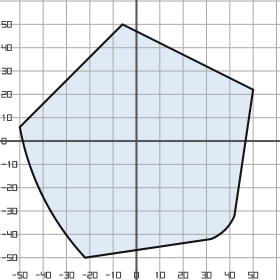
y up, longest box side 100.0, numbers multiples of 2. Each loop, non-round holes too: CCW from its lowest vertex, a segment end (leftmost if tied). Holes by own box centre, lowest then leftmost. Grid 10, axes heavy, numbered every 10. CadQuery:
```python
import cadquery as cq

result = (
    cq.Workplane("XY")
    .moveTo(-22.0, -50.0)
    .lineTo(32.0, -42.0)
    .threePointArc((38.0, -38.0), (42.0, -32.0))
    .lineTo(50.0, 22.0)
    .lineTo(-6.0, 50.0)
    .lineTo(-50.0, 6.0)
    .threePointArc((-40.0, -24.0), (-22.0, -50.0))
    .close()
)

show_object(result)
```